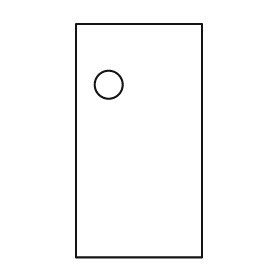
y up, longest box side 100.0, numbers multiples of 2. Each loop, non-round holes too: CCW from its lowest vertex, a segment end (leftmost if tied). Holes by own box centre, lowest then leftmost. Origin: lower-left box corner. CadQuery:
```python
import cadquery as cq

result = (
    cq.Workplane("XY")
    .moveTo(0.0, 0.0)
    .lineTo(54.0, 0.0)
    .lineTo(54.0, 100.0)
    .lineTo(0.0, 100.0)
    .close()
    .moveTo(14.0, 74.0)
    .circle(6.0)
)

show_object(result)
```